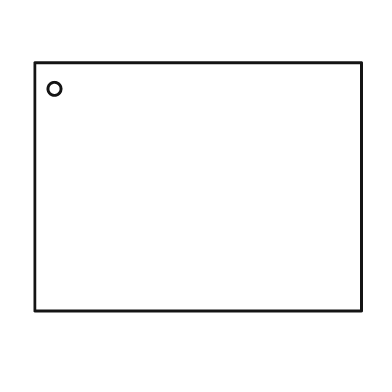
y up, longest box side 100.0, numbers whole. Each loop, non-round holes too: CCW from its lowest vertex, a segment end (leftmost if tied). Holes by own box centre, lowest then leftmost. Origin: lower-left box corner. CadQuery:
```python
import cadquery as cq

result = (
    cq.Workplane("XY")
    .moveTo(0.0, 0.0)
    .lineTo(100.0, 0.0)
    .lineTo(100.0, 76.0)
    .lineTo(0.0, 76.0)
    .close()
    .moveTo(6.0, 68.0)
    .circle(2.0)
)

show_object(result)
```